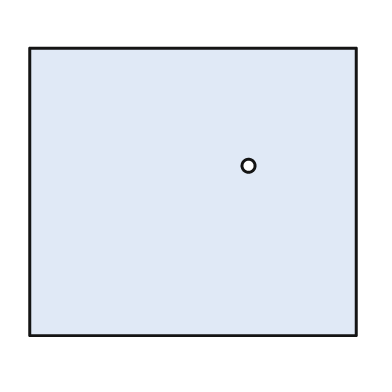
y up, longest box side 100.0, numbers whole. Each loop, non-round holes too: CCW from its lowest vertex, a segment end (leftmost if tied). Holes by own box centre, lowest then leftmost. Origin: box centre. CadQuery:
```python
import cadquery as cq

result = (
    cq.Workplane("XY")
    .moveTo(-50.0, -44.0)
    .lineTo(50.0, -44.0)
    .lineTo(50.0, 44.0)
    .lineTo(-50.0, 44.0)
    .close()
    .moveTo(17.0, 8.0)
    .circle(2.0)
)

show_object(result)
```